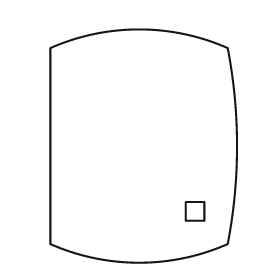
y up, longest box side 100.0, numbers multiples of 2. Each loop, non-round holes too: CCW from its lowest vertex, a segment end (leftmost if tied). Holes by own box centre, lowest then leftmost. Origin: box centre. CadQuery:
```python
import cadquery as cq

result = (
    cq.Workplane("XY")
    .moveTo(-40.0, -42.0)
    .threePointArc((-2.0, -50.0), (36.0, -42.0))
    .threePointArc((40.0, 0.0), (36.0, 42.0))
    .threePointArc((-2.0, 50.0), (-40.0, 42.0))
    .close()
    .moveTo(18.0, -32.0)
    .lineTo(26.0, -32.0)
    .lineTo(26.0, -24.0)
    .lineTo(18.0, -24.0)
    .close()
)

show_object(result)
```